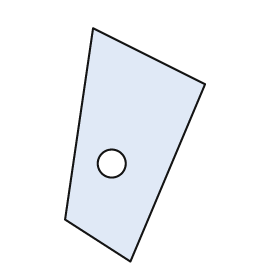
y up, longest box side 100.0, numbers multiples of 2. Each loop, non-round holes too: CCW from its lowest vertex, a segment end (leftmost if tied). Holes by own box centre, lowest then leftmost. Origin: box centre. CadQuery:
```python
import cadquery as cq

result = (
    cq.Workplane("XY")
    .moveTo(-2.0, -50.0)
    .lineTo(30.0, 26.0)
    .lineTo(-18.0, 50.0)
    .lineTo(-30.0, -32.0)
    .close()
    .moveTo(-10.0, -8.0)
    .circle(6.0)
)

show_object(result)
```